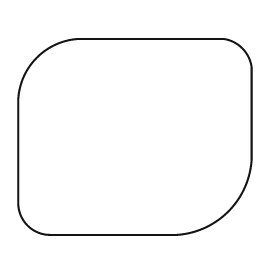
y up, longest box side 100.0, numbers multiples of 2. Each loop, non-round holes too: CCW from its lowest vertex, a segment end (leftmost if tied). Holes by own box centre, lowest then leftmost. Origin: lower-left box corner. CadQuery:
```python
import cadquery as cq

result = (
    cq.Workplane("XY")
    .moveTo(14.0, 0.0)
    .lineTo(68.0, 0.0)
    .threePointArc((90.0, 10.0), (100.0, 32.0))
    .lineTo(100.0, 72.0)
    .threePointArc((96.0, 80.0), (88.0, 84.0))
    .lineTo(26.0, 84.0)
    .threePointArc((8.0, 76.0), (0.0, 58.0))
    .lineTo(0.0, 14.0)
    .threePointArc((4.0, 4.0), (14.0, 0.0))
    .close()
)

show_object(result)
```